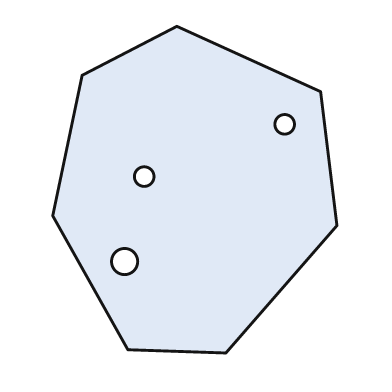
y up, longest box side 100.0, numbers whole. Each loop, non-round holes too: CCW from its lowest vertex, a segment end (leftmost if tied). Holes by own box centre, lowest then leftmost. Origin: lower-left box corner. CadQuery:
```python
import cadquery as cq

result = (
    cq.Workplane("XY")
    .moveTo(53.0, 0.0)
    .lineTo(87.0, 39.0)
    .lineTo(82.0, 80.0)
    .lineTo(38.0, 100.0)
    .lineTo(9.0, 85.0)
    .lineTo(0.0, 42.0)
    .lineTo(23.0, 1.0)
    .close()
    .moveTo(22.0, 28.0)
    .circle(4.0)
    .moveTo(28.0, 54.0)
    .circle(3.0)
    .moveTo(71.0, 70.0)
    .circle(3.0)
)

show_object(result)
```